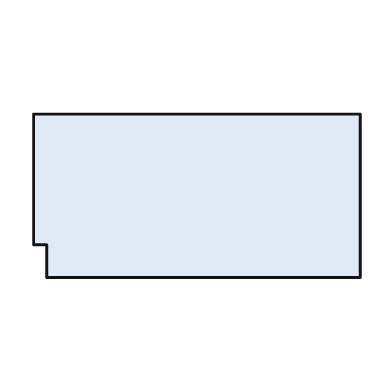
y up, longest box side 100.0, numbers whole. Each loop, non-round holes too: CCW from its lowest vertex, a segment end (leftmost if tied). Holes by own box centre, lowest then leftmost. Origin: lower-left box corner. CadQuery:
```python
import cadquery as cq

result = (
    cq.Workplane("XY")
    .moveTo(4.0, 0.0)
    .lineTo(100.0, 0.0)
    .lineTo(100.0, 50.0)
    .lineTo(0.0, 50.0)
    .lineTo(0.0, 10.0)
    .lineTo(4.0, 10.0)
    .close()
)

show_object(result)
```